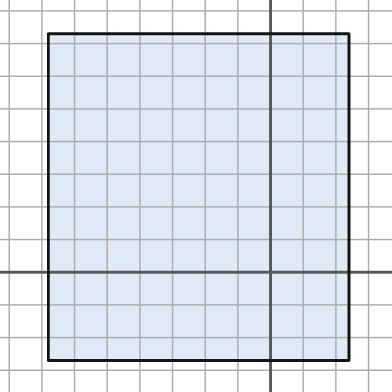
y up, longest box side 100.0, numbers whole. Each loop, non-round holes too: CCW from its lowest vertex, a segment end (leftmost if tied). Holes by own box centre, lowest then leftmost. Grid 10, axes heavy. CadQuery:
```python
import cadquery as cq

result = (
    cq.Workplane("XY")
    .moveTo(-68.0, -27.0)
    .lineTo(24.0, -27.0)
    .lineTo(24.0, 73.0)
    .lineTo(-68.0, 73.0)
    .close()
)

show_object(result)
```